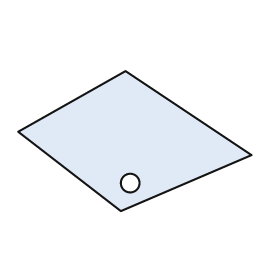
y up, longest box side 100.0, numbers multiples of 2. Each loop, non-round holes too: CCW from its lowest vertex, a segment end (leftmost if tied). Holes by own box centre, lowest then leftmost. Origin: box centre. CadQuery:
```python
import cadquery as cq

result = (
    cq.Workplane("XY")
    .moveTo(-6.0, -30.0)
    .lineTo(50.0, -6.0)
    .lineTo(-4.0, 30.0)
    .lineTo(-50.0, 4.0)
    .close()
    .moveTo(-2.0, -18.0)
    .circle(4.0)
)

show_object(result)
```